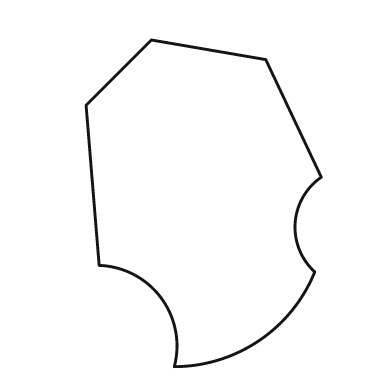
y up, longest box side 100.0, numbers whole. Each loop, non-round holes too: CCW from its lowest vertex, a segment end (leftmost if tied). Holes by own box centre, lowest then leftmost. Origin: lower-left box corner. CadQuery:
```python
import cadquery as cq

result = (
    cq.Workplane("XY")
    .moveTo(27.0, 0.0)
    .threePointArc((53.0, 8.0), (70.0, 29.0))
    .threePointArc((64.0, 44.0), (72.0, 58.0))
    .lineTo(55.0, 94.0)
    .lineTo(20.0, 100.0)
    .lineTo(0.0, 80.0)
    .lineTo(4.0, 31.0)
    .threePointArc((23.0, 21.0), (27.0, 0.0))
    .close()
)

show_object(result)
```